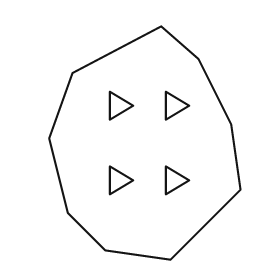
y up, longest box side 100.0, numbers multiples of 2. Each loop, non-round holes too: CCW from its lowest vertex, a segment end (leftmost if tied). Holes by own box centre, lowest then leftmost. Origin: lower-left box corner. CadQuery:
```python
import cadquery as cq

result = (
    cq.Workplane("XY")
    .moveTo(52.0, 0.0)
    .lineTo(82.0, 30.0)
    .lineTo(78.0, 58.0)
    .lineTo(64.0, 86.0)
    .lineTo(48.0, 100.0)
    .lineTo(10.0, 80.0)
    .lineTo(0.0, 52.0)
    .lineTo(8.0, 20.0)
    .lineTo(24.0, 4.0)
    .close()
    .moveTo(26.0, 28.0)
    .lineTo(36.0, 34.0)
    .lineTo(26.0, 40.0)
    .close()
    .moveTo(50.0, 28.0)
    .lineTo(60.0, 34.0)
    .lineTo(50.0, 40.0)
    .close()
    .moveTo(26.0, 60.0)
    .lineTo(36.0, 66.0)
    .lineTo(26.0, 72.0)
    .close()
    .moveTo(50.0, 60.0)
    .lineTo(60.0, 66.0)
    .lineTo(50.0, 72.0)
    .close()
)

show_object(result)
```